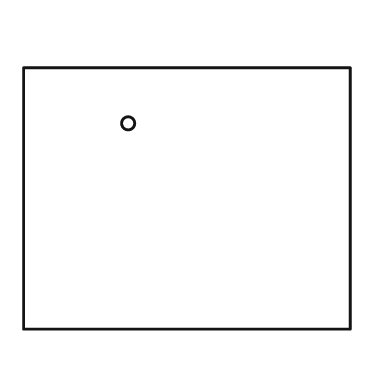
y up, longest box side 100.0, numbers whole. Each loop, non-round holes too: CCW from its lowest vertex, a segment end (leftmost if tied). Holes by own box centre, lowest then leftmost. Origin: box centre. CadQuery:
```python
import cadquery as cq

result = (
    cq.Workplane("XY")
    .moveTo(-50.0, -40.0)
    .lineTo(50.0, -40.0)
    .lineTo(50.0, 40.0)
    .lineTo(-50.0, 40.0)
    .close()
    .moveTo(-18.0, 23.0)
    .circle(2.0)
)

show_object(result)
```